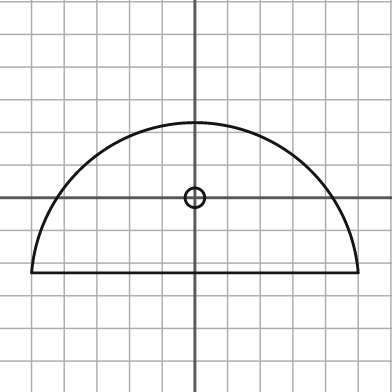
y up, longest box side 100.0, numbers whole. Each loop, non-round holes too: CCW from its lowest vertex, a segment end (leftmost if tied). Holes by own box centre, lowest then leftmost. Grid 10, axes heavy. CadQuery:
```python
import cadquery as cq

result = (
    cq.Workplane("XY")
    .moveTo(-50.0, -23.0)
    .lineTo(50.0, -23.0)
    .threePointArc((0.0, 23.0), (-50.0, -23.0))
    .close()
    .moveTo(0.0, 0.0)
    .circle(3.0)
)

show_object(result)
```